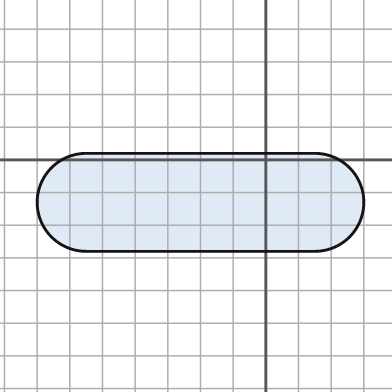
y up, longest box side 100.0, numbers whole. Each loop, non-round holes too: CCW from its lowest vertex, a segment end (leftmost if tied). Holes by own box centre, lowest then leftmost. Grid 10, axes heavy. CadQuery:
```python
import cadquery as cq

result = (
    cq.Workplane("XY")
    .moveTo(-55.0, -28.0)
    .lineTo(15.0, -28.0)
    .threePointArc((30.0, -13.0), (15.0, 2.0))
    .lineTo(-55.0, 2.0)
    .threePointArc((-70.0, -13.0), (-55.0, -28.0))
    .close()
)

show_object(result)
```